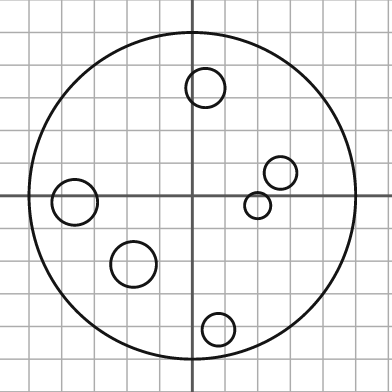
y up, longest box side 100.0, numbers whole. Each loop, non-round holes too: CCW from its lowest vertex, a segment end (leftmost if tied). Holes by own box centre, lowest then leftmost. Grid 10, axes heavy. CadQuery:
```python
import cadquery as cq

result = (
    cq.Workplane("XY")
    .moveTo(0.0, 0.0)
    .circle(50.0)
    .moveTo(8.0, -41.0)
    .circle(5.0)
    .moveTo(-18.0, -21.0)
    .circle(7.0)
    .moveTo(20.0, -3.0)
    .circle(4.0)
    .moveTo(-36.0, -2.0)
    .circle(7.0)
    .moveTo(27.0, 7.0)
    .circle(5.0)
    .moveTo(4.0, 33.0)
    .circle(6.0)
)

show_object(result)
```